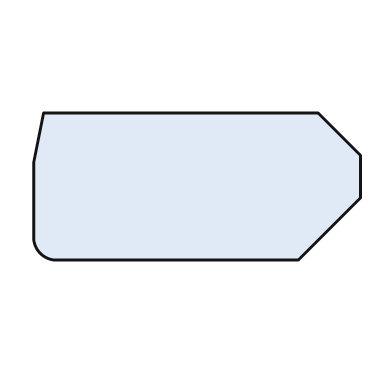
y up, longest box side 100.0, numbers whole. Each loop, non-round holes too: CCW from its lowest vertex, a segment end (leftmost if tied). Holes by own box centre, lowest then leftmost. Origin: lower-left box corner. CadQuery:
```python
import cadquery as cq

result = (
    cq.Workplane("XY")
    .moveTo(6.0, 0.0)
    .lineTo(81.0, 0.0)
    .lineTo(100.0, 19.0)
    .lineTo(100.0, 32.0)
    .lineTo(87.0, 45.0)
    .lineTo(3.0, 45.0)
    .lineTo(0.0, 30.0)
    .lineTo(0.0, 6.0)
    .threePointArc((2.0, 2.0), (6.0, 0.0))
    .close()
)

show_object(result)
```